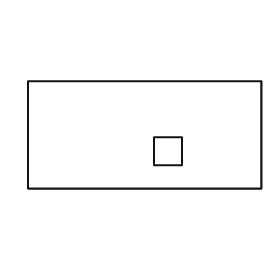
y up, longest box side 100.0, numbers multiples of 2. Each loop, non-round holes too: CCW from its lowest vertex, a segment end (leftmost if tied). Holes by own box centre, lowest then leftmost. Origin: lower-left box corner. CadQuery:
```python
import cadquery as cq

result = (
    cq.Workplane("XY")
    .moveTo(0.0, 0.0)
    .lineTo(100.0, 0.0)
    .lineTo(100.0, 46.0)
    .lineTo(0.0, 46.0)
    .close()
    .moveTo(54.0, 10.0)
    .lineTo(66.0, 10.0)
    .lineTo(66.0, 22.0)
    .lineTo(54.0, 22.0)
    .close()
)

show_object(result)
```